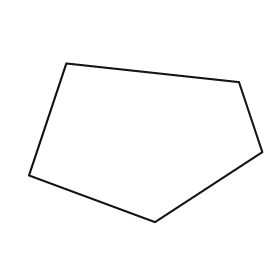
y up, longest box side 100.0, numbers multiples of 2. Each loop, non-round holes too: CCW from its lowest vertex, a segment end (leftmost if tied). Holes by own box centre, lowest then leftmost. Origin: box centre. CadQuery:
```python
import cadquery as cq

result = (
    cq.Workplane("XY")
    .moveTo(4.0, -34.0)
    .lineTo(50.0, -4.0)
    .lineTo(40.0, 26.0)
    .lineTo(-34.0, 34.0)
    .lineTo(-50.0, -14.0)
    .close()
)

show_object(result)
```